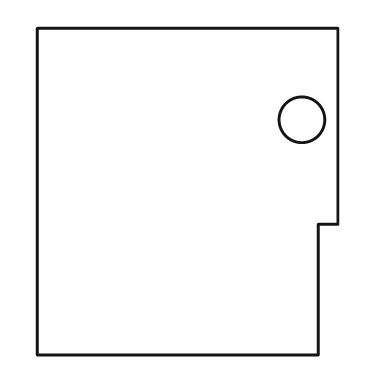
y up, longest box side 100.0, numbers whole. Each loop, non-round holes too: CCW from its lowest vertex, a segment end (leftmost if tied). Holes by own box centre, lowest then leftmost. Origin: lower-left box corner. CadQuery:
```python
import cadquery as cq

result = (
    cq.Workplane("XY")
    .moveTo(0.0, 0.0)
    .lineTo(86.0, 0.0)
    .lineTo(86.0, 40.0)
    .lineTo(92.0, 40.0)
    .lineTo(92.0, 100.0)
    .lineTo(0.0, 100.0)
    .close()
    .moveTo(81.0, 72.0)
    .circle(7.0)
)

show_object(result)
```